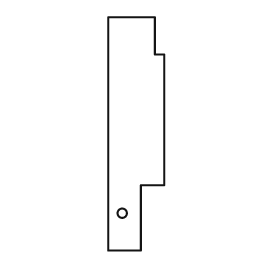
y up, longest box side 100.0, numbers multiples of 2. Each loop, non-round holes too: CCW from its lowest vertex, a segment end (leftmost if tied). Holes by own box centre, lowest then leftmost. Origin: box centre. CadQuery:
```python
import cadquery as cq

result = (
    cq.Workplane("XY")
    .moveTo(-12.0, -50.0)
    .lineTo(2.0, -50.0)
    .lineTo(2.0, -22.0)
    .lineTo(12.0, -22.0)
    .lineTo(12.0, 34.0)
    .lineTo(8.0, 34.0)
    .lineTo(8.0, 50.0)
    .lineTo(-12.0, 50.0)
    .close()
    .moveTo(-6.0, -34.0)
    .circle(2.0)
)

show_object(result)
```